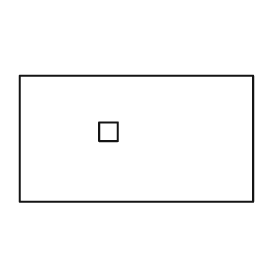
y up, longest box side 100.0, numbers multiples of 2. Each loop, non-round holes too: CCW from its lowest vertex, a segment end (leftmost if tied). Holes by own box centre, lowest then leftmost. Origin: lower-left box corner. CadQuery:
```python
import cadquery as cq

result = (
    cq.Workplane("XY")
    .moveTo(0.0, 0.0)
    .lineTo(100.0, 0.0)
    .lineTo(100.0, 54.0)
    .lineTo(0.0, 54.0)
    .close()
    .moveTo(34.0, 26.0)
    .lineTo(42.0, 26.0)
    .lineTo(42.0, 34.0)
    .lineTo(34.0, 34.0)
    .close()
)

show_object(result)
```